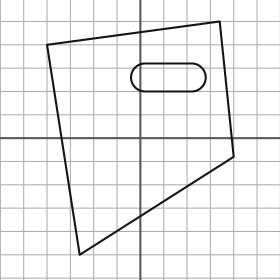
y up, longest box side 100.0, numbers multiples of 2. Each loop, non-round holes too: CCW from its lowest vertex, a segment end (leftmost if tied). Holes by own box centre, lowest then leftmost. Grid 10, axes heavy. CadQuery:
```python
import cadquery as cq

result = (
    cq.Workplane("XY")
    .moveTo(-26.0, -50.0)
    .lineTo(40.0, -8.0)
    .lineTo(34.0, 50.0)
    .lineTo(-40.0, 40.0)
    .close()
    .moveTo(2.0, 20.0)
    .lineTo(22.0, 20.0)
    .threePointArc((28.0, 26.0), (22.0, 32.0))
    .lineTo(2.0, 32.0)
    .threePointArc((-4.0, 26.0), (2.0, 20.0))
    .close()
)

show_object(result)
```